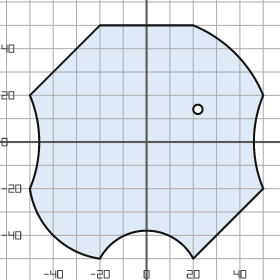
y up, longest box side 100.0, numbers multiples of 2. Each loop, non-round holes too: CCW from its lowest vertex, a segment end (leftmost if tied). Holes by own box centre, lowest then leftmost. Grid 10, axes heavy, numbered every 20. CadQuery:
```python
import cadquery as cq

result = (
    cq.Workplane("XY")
    .moveTo(-20.0, -50.0)
    .threePointArc((0.0, -38.0), (20.0, -50.0))
    .lineTo(50.0, -20.0)
    .threePointArc((46.0, 0.0), (50.0, 20.0))
    .threePointArc((38.0, 38.0), (20.0, 50.0))
    .lineTo(-20.0, 50.0)
    .lineTo(-50.0, 20.0)
    .threePointArc((-46.0, 0.0), (-50.0, -20.0))
    .threePointArc((-40.0, -40.0), (-20.0, -50.0))
    .close()
    .moveTo(22.0, 14.0)
    .circle(2.0)
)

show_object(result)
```